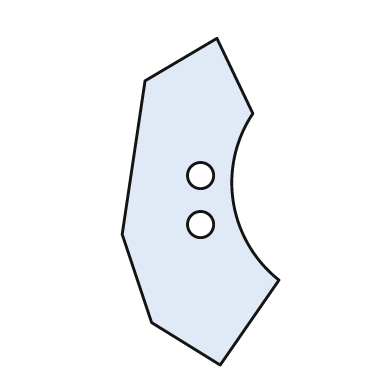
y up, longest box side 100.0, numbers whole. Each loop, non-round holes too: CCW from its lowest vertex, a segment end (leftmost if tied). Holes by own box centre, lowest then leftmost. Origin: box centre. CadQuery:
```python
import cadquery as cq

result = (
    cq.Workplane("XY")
    .moveTo(6.0, -50.0)
    .lineTo(24.0, -24.0)
    .threePointArc((10.0, 0.0), (16.0, 27.0))
    .lineTo(5.0, 50.0)
    .lineTo(-17.0, 37.0)
    .lineTo(-24.0, -10.0)
    .lineTo(-15.0, -37.0)
    .close()
    .moveTo(0.0, -7.0)
    .circle(4.0)
    .moveTo(0.0, 8.0)
    .circle(4.0)
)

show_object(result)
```